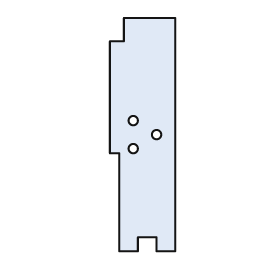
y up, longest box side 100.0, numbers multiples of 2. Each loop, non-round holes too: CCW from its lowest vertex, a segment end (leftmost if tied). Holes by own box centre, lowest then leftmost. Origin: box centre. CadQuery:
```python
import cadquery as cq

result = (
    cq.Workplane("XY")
    .moveTo(-10.0, -50.0)
    .lineTo(-2.0, -50.0)
    .lineTo(-2.0, -44.0)
    .lineTo(6.0, -44.0)
    .lineTo(6.0, -50.0)
    .lineTo(14.0, -50.0)
    .lineTo(14.0, 50.0)
    .lineTo(-8.0, 50.0)
    .lineTo(-8.0, 40.0)
    .lineTo(-14.0, 40.0)
    .lineTo(-14.0, -8.0)
    .lineTo(-10.0, -8.0)
    .close()
    .moveTo(-4.0, -6.0)
    .circle(2.0)
    .moveTo(6.0, 0.0)
    .circle(2.0)
    .moveTo(-4.0, 6.0)
    .circle(2.0)
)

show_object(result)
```